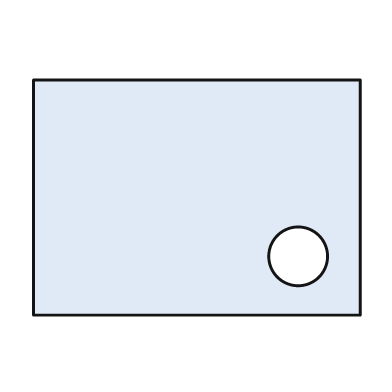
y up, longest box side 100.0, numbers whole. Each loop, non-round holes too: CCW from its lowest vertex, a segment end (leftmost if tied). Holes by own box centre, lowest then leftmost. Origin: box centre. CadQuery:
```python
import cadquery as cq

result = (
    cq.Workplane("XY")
    .moveTo(-50.0, -36.0)
    .lineTo(50.0, -36.0)
    .lineTo(50.0, 36.0)
    .lineTo(-50.0, 36.0)
    .close()
    .moveTo(31.0, -18.0)
    .circle(9.0)
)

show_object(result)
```